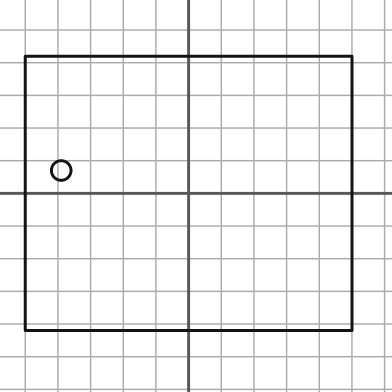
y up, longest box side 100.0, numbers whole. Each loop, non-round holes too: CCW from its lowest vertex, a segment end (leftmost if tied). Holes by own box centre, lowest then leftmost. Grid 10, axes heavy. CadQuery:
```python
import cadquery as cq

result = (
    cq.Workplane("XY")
    .moveTo(-50.0, -42.0)
    .lineTo(50.0, -42.0)
    .lineTo(50.0, 42.0)
    .lineTo(-50.0, 42.0)
    .close()
    .moveTo(-39.0, 7.0)
    .circle(3.0)
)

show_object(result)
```